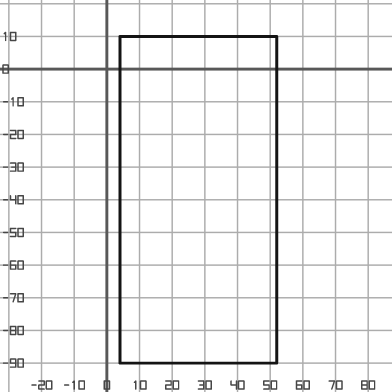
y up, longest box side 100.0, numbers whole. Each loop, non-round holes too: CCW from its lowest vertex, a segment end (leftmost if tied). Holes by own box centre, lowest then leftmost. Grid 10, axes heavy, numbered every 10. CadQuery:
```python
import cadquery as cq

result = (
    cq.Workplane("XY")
    .moveTo(4.0, -90.0)
    .lineTo(52.0, -90.0)
    .lineTo(52.0, 10.0)
    .lineTo(4.0, 10.0)
    .close()
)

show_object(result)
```